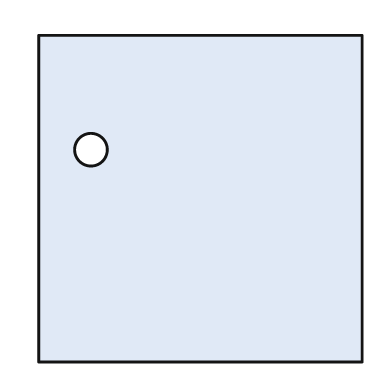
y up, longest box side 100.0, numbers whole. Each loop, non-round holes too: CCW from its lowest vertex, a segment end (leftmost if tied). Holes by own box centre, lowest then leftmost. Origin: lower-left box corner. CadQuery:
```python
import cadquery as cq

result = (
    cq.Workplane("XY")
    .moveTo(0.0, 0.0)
    .lineTo(99.0, 0.0)
    .lineTo(99.0, 100.0)
    .lineTo(0.0, 100.0)
    .close()
    .moveTo(16.0, 65.0)
    .circle(5.0)
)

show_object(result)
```